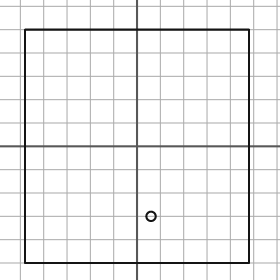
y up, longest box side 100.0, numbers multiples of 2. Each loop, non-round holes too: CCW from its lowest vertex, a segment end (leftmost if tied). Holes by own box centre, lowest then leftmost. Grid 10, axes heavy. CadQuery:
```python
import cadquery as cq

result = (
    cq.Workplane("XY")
    .moveTo(-48.0, -50.0)
    .lineTo(48.0, -50.0)
    .lineTo(48.0, 50.0)
    .lineTo(-48.0, 50.0)
    .close()
    .moveTo(6.0, -30.0)
    .circle(2.0)
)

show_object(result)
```